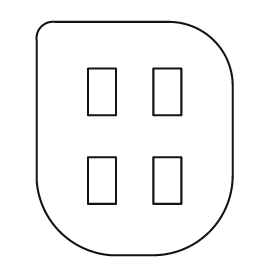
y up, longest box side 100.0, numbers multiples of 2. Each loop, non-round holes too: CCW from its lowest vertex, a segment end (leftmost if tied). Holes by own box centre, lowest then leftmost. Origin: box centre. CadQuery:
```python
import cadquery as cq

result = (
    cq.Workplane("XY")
    .moveTo(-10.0, -50.0)
    .lineTo(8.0, -50.0)
    .threePointArc((32.0, -40.0), (42.0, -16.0))
    .lineTo(42.0, 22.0)
    .threePointArc((34.0, 42.0), (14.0, 50.0))
    .lineTo(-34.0, 50.0)
    .threePointArc((-40.0, 48.0), (-42.0, 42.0))
    .lineTo(-42.0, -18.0)
    .threePointArc((-32.0, -40.0), (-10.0, -50.0))
    .close()
    .moveTo(-20.0, -28.0)
    .lineTo(-8.0, -28.0)
    .lineTo(-8.0, -8.0)
    .lineTo(-20.0, -8.0)
    .close()
    .moveTo(8.0, -28.0)
    .lineTo(20.0, -28.0)
    .lineTo(20.0, -8.0)
    .lineTo(8.0, -8.0)
    .close()
    .moveTo(-20.0, 10.0)
    .lineTo(-8.0, 10.0)
    .lineTo(-8.0, 30.0)
    .lineTo(-20.0, 30.0)
    .close()
    .moveTo(8.0, 10.0)
    .lineTo(20.0, 10.0)
    .lineTo(20.0, 30.0)
    .lineTo(8.0, 30.0)
    .close()
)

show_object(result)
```